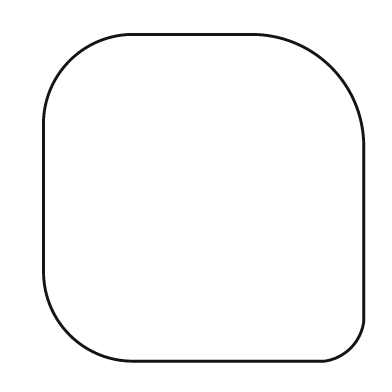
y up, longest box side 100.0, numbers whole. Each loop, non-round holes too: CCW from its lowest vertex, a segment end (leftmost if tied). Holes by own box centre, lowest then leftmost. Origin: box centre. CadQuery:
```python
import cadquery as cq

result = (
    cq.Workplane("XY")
    .moveTo(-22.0, -50.0)
    .lineTo(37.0, -50.0)
    .threePointArc((45.0, -46.0), (49.0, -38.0))
    .lineTo(49.0, 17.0)
    .threePointArc((39.0, 40.0), (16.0, 50.0))
    .lineTo(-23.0, 50.0)
    .threePointArc((-41.0, 42.0), (-49.0, 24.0))
    .lineTo(-49.0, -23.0)
    .threePointArc((-41.0, -42.0), (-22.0, -50.0))
    .close()
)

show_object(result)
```